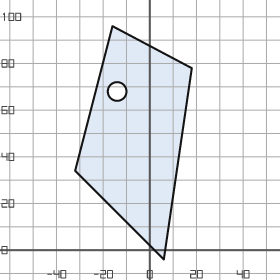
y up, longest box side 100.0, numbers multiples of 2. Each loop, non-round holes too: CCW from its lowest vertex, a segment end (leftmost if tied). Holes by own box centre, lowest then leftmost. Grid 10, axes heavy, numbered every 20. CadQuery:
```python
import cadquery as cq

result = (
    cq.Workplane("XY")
    .moveTo(6.0, -4.0)
    .lineTo(18.0, 78.0)
    .lineTo(-16.0, 96.0)
    .lineTo(-32.0, 34.0)
    .close()
    .moveTo(-14.0, 68.0)
    .circle(4.0)
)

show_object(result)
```